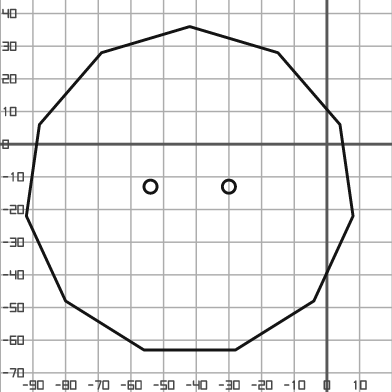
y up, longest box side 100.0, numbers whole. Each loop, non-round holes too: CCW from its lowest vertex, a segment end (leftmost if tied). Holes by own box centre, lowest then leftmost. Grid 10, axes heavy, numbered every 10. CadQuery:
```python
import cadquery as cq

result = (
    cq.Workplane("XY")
    .moveTo(-56.0, -63.0)
    .lineTo(-28.0, -63.0)
    .lineTo(-4.0, -48.0)
    .lineTo(8.0, -22.0)
    .lineTo(4.0, 6.0)
    .lineTo(-15.0, 28.0)
    .lineTo(-42.0, 36.0)
    .lineTo(-69.0, 28.0)
    .lineTo(-88.0, 6.0)
    .lineTo(-92.0, -22.0)
    .lineTo(-80.0, -48.0)
    .close()
    .moveTo(-54.0, -13.0)
    .circle(2.0)
    .moveTo(-30.0, -13.0)
    .circle(2.0)
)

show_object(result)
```